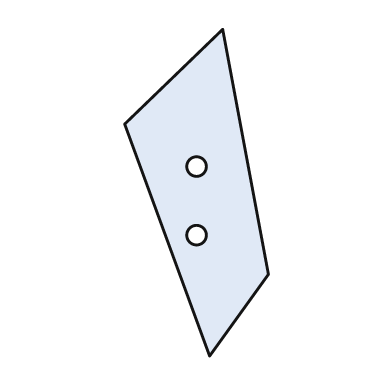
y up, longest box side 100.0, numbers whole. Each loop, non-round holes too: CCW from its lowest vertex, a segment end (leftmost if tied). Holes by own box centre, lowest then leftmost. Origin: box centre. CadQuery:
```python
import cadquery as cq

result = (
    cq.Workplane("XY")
    .moveTo(4.0, -50.0)
    .lineTo(22.0, -25.0)
    .lineTo(8.0, 50.0)
    .lineTo(-22.0, 21.0)
    .close()
    .moveTo(0.0, -13.0)
    .circle(3.0)
    .moveTo(0.0, 8.0)
    .circle(3.0)
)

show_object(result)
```